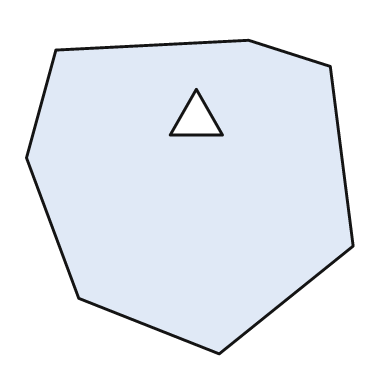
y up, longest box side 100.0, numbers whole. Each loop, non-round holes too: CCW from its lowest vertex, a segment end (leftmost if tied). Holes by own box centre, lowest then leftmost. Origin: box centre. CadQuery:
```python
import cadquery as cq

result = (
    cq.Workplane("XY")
    .moveTo(9.0, -48.0)
    .lineTo(50.0, -15.0)
    .lineTo(43.0, 40.0)
    .lineTo(18.0, 48.0)
    .lineTo(-41.0, 45.0)
    .lineTo(-50.0, 12.0)
    .lineTo(-34.0, -31.0)
    .close()
    .moveTo(-6.0, 19.0)
    .lineTo(10.0, 19.0)
    .lineTo(2.0, 33.0)
    .close()
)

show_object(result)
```